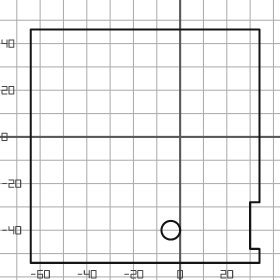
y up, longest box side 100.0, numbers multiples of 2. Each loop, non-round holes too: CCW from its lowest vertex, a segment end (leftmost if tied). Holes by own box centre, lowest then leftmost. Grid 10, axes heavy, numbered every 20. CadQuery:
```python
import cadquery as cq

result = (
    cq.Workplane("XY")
    .moveTo(-64.0, -54.0)
    .lineTo(34.0, -54.0)
    .lineTo(34.0, -48.0)
    .lineTo(30.0, -48.0)
    .lineTo(30.0, -28.0)
    .lineTo(34.0, -28.0)
    .lineTo(34.0, 46.0)
    .lineTo(-64.0, 46.0)
    .close()
    .moveTo(-4.0, -40.0)
    .circle(4.0)
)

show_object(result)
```